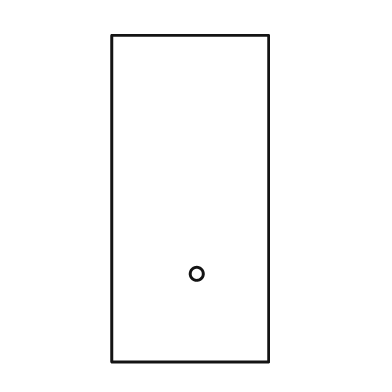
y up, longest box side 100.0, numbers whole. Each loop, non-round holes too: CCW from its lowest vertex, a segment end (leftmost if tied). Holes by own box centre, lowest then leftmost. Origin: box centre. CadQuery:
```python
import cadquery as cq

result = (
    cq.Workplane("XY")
    .moveTo(-24.0, -50.0)
    .lineTo(24.0, -50.0)
    .lineTo(24.0, 50.0)
    .lineTo(-24.0, 50.0)
    .close()
    .moveTo(2.0, -23.0)
    .circle(2.0)
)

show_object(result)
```